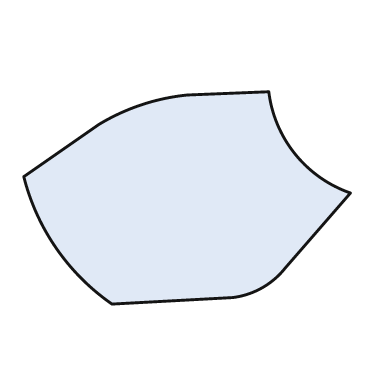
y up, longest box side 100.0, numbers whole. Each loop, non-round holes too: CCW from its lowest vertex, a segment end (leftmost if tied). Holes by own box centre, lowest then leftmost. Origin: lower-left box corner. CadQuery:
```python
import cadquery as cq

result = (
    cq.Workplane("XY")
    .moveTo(27.0, 0.0)
    .lineTo(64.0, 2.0)
    .threePointArc((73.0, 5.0), (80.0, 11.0))
    .lineTo(100.0, 34.0)
    .threePointArc((83.0, 46.0), (75.0, 65.0))
    .lineTo(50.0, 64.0)
    .threePointArc((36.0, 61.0), (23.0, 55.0))
    .lineTo(0.0, 39.0)
    .threePointArc((10.0, 17.0), (27.0, 0.0))
    .close()
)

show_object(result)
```